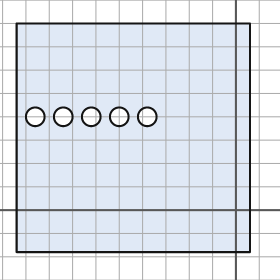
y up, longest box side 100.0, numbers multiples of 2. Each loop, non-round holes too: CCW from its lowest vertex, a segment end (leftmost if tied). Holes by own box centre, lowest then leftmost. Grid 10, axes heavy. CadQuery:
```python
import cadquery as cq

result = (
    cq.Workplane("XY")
    .moveTo(-94.0, -18.0)
    .lineTo(6.0, -18.0)
    .lineTo(6.0, 80.0)
    .lineTo(-94.0, 80.0)
    .close()
    .moveTo(-86.0, 40.0)
    .circle(4.0)
    .moveTo(-74.0, 40.0)
    .circle(4.0)
    .moveTo(-62.0, 40.0)
    .circle(4.0)
    .moveTo(-50.0, 40.0)
    .circle(4.0)
    .moveTo(-38.0, 40.0)
    .circle(4.0)
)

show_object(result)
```